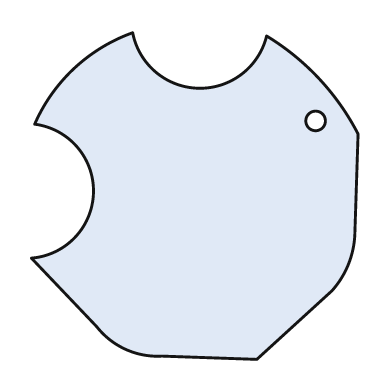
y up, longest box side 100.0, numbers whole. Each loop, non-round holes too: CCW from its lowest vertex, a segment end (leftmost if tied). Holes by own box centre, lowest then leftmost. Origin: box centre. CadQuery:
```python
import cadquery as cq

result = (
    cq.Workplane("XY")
    .moveTo(19.0, -50.0)
    .lineTo(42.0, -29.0)
    .threePointArc((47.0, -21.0), (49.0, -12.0))
    .lineTo(50.0, 19.0)
    .threePointArc((38.0, 36.0), (22.0, 49.0))
    .threePointArc((1.0, 33.0), (-19.0, 50.0))
    .threePointArc((-37.0, 39.0), (-49.0, 22.0))
    .threePointArc((-31.0, 1.0), (-50.0, -19.0))
    .lineTo(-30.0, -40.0)
    .threePointArc((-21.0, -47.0), (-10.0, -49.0))
    .close()
    .moveTo(37.0, 23.0)
    .circle(3.0)
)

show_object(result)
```